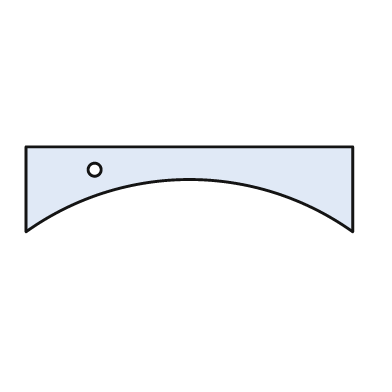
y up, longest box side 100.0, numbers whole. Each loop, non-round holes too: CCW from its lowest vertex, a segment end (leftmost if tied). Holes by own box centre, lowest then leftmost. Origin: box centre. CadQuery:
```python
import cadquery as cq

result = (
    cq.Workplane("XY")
    .moveTo(-50.0, -13.0)
    .threePointArc((0.0, 3.0), (50.0, -13.0))
    .lineTo(50.0, 13.0)
    .lineTo(-50.0, 13.0)
    .close()
    .moveTo(-29.0, 6.0)
    .circle(2.0)
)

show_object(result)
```